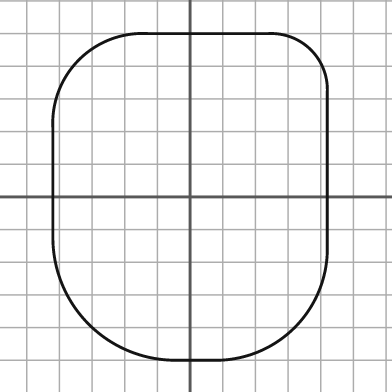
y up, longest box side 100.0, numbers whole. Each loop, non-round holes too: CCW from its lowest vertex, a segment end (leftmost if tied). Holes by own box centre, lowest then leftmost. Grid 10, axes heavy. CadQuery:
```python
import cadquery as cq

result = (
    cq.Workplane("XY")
    .moveTo(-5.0, -50.0)
    .lineTo(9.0, -50.0)
    .threePointArc((32.0, -40.0), (42.0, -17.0))
    .lineTo(42.0, 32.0)
    .threePointArc((37.0, 45.0), (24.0, 50.0))
    .lineTo(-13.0, 50.0)
    .threePointArc((-34.0, 42.0), (-42.0, 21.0))
    .lineTo(-42.0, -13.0)
    .threePointArc((-31.0, -39.0), (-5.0, -50.0))
    .close()
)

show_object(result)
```